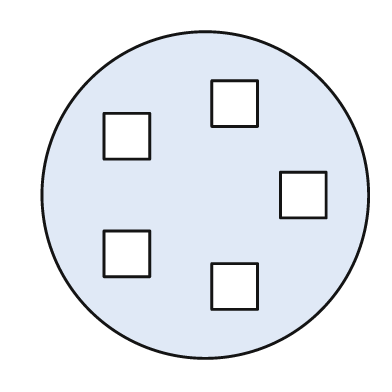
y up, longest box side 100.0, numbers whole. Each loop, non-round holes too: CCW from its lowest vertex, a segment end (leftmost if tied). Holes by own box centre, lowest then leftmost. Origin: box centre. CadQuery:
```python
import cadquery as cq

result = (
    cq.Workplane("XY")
    .moveTo(0.0, 0.0)
    .circle(50.0)
    .moveTo(2.0, -35.0)
    .lineTo(16.0, -35.0)
    .lineTo(16.0, -21.0)
    .lineTo(2.0, -21.0)
    .close()
    .moveTo(-31.0, -25.0)
    .lineTo(-17.0, -25.0)
    .lineTo(-17.0, -11.0)
    .lineTo(-31.0, -11.0)
    .close()
    .moveTo(23.0, -7.0)
    .lineTo(37.0, -7.0)
    .lineTo(37.0, 7.0)
    .lineTo(23.0, 7.0)
    .close()
    .moveTo(-31.0, 11.0)
    .lineTo(-17.0, 11.0)
    .lineTo(-17.0, 25.0)
    .lineTo(-31.0, 25.0)
    .close()
    .moveTo(2.0, 21.0)
    .lineTo(16.0, 21.0)
    .lineTo(16.0, 35.0)
    .lineTo(2.0, 35.0)
    .close()
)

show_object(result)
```